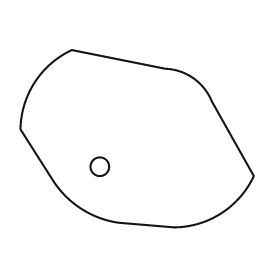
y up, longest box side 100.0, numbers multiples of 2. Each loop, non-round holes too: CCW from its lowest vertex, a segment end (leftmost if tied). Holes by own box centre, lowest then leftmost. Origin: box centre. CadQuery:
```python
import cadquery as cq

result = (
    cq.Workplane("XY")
    .moveTo(16.0, -38.0)
    .threePointArc((36.0, -32.0), (50.0, -16.0))
    .lineTo(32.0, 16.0)
    .threePointArc((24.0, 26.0), (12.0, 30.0))
    .lineTo(-28.0, 38.0)
    .threePointArc((-44.0, 24.0), (-50.0, 4.0))
    .lineTo(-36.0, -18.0)
    .threePointArc((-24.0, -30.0), (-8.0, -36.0))
    .close()
    .moveTo(-16.0, -12.0)
    .circle(4.0)
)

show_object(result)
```